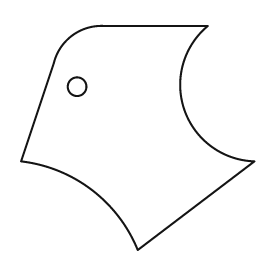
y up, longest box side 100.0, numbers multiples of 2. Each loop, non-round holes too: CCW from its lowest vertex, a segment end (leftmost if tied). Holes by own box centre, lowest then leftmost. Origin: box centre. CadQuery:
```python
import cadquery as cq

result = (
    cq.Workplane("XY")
    .moveTo(0.0, -48.0)
    .lineTo(50.0, -10.0)
    .threePointArc((20.0, 12.0), (30.0, 48.0))
    .lineTo(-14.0, 48.0)
    .threePointArc((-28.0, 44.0), (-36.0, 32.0))
    .lineTo(-50.0, -10.0)
    .threePointArc((-20.0, -22.0), (0.0, -48.0))
    .close()
    .moveTo(-26.0, 22.0)
    .circle(4.0)
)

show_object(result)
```